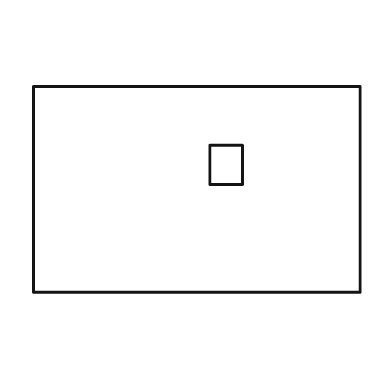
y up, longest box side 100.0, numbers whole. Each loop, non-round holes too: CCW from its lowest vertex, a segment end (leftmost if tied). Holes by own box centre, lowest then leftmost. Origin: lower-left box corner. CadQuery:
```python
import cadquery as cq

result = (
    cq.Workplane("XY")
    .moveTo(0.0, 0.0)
    .lineTo(100.0, 0.0)
    .lineTo(100.0, 63.0)
    .lineTo(0.0, 63.0)
    .close()
    .moveTo(54.0, 33.0)
    .lineTo(64.0, 33.0)
    .lineTo(64.0, 45.0)
    .lineTo(54.0, 45.0)
    .close()
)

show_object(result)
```